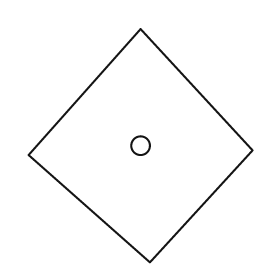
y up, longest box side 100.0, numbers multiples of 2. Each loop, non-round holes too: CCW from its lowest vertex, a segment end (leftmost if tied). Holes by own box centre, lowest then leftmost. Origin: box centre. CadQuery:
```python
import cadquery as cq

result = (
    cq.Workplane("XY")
    .moveTo(4.0, -50.0)
    .lineTo(48.0, -2.0)
    .lineTo(0.0, 50.0)
    .lineTo(-48.0, -4.0)
    .close()
    .moveTo(0.0, 0.0)
    .circle(4.0)
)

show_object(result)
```